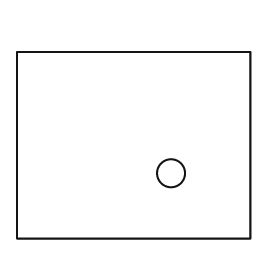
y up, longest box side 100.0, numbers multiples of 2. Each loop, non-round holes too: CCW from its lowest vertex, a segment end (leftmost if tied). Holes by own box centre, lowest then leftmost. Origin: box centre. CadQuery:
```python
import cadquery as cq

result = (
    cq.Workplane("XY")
    .moveTo(-50.0, -40.0)
    .lineTo(50.0, -40.0)
    .lineTo(50.0, 40.0)
    .lineTo(-50.0, 40.0)
    .close()
    .moveTo(16.0, -12.0)
    .circle(6.0)
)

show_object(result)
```